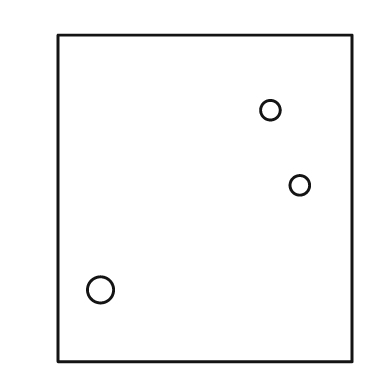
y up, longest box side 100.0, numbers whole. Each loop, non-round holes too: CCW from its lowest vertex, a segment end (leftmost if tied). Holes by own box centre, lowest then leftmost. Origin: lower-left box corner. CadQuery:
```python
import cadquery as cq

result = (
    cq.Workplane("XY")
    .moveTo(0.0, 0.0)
    .lineTo(90.0, 0.0)
    .lineTo(90.0, 100.0)
    .lineTo(0.0, 100.0)
    .close()
    .moveTo(13.0, 22.0)
    .circle(4.0)
    .moveTo(74.0, 54.0)
    .circle(3.0)
    .moveTo(65.0, 77.0)
    .circle(3.0)
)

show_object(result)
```